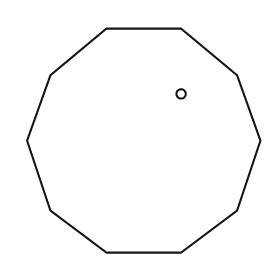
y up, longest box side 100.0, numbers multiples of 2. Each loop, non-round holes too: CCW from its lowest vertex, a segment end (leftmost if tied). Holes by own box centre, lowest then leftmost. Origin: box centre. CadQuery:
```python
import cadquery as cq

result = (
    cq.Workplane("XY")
    .moveTo(-16.0, -48.0)
    .lineTo(16.0, -48.0)
    .lineTo(40.0, -30.0)
    .lineTo(50.0, 0.0)
    .lineTo(40.0, 28.0)
    .lineTo(16.0, 48.0)
    .lineTo(-16.0, 48.0)
    .lineTo(-40.0, 28.0)
    .lineTo(-50.0, 0.0)
    .lineTo(-40.0, -30.0)
    .close()
    .moveTo(16.0, 20.0)
    .circle(2.0)
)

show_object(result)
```